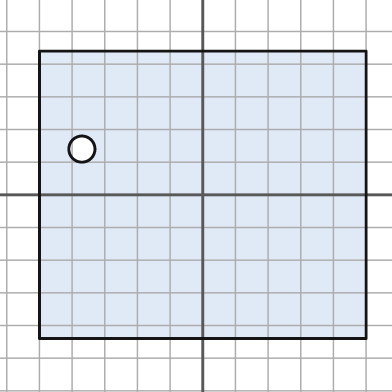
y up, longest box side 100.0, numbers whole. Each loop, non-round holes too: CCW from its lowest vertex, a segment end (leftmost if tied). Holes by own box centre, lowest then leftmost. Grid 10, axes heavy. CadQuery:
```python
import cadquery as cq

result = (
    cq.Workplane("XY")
    .moveTo(-50.0, -44.0)
    .lineTo(50.0, -44.0)
    .lineTo(50.0, 44.0)
    .lineTo(-50.0, 44.0)
    .close()
    .moveTo(-37.0, 14.0)
    .circle(4.0)
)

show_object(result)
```